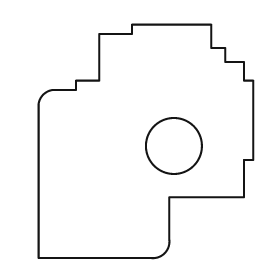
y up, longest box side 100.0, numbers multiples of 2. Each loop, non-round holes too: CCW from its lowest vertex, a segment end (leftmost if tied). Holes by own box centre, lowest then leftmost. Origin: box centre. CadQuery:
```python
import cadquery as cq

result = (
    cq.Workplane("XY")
    .moveTo(-46.0, -50.0)
    .lineTo(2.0, -50.0)
    .threePointArc((8.0, -48.0), (10.0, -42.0))
    .lineTo(10.0, -24.0)
    .lineTo(42.0, -24.0)
    .lineTo(42.0, -8.0)
    .lineTo(46.0, -8.0)
    .lineTo(46.0, 26.0)
    .lineTo(42.0, 26.0)
    .lineTo(42.0, 34.0)
    .lineTo(34.0, 34.0)
    .lineTo(34.0, 40.0)
    .lineTo(28.0, 40.0)
    .lineTo(28.0, 50.0)
    .lineTo(-6.0, 50.0)
    .lineTo(-6.0, 46.0)
    .lineTo(-20.0, 46.0)
    .lineTo(-20.0, 26.0)
    .lineTo(-30.0, 26.0)
    .lineTo(-30.0, 22.0)
    .lineTo(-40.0, 22.0)
    .threePointArc((-44.0, 20.0), (-46.0, 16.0))
    .close()
    .moveTo(12.0, -2.0)
    .circle(12.0)
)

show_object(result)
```